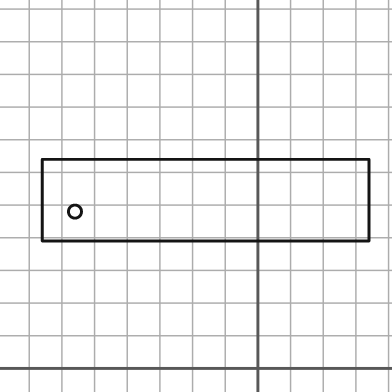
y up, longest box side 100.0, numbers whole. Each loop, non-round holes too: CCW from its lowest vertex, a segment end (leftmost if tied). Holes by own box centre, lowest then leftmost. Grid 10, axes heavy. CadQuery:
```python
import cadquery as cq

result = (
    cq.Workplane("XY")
    .moveTo(-66.0, 39.0)
    .lineTo(34.0, 39.0)
    .lineTo(34.0, 64.0)
    .lineTo(-66.0, 64.0)
    .close()
    .moveTo(-56.0, 48.0)
    .circle(2.0)
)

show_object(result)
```